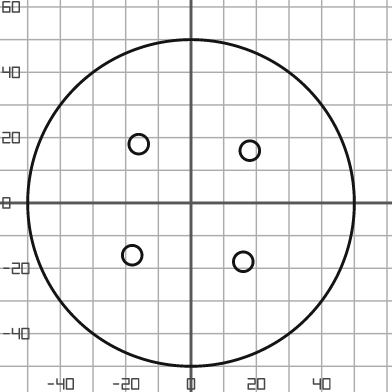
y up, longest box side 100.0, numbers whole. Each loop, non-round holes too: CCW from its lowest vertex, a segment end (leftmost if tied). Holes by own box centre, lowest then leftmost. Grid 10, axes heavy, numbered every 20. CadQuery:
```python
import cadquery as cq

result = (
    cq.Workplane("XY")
    .moveTo(0.0, 0.0)
    .circle(50.0)
    .moveTo(16.0, -18.0)
    .circle(3.0)
    .moveTo(-18.0, -16.0)
    .circle(3.0)
    .moveTo(18.0, 16.0)
    .circle(3.0)
    .moveTo(-16.0, 18.0)
    .circle(3.0)
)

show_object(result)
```